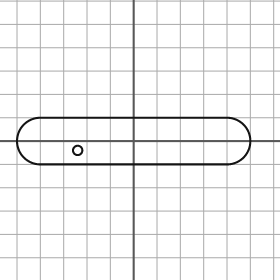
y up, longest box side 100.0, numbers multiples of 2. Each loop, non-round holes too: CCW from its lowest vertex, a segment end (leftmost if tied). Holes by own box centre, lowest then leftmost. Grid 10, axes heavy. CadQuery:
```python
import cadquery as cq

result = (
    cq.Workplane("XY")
    .moveTo(-40.0, -10.0)
    .lineTo(40.0, -10.0)
    .threePointArc((50.0, 0.0), (40.0, 10.0))
    .lineTo(-40.0, 10.0)
    .threePointArc((-50.0, 0.0), (-40.0, -10.0))
    .close()
    .moveTo(-24.0, -4.0)
    .circle(2.0)
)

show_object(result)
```